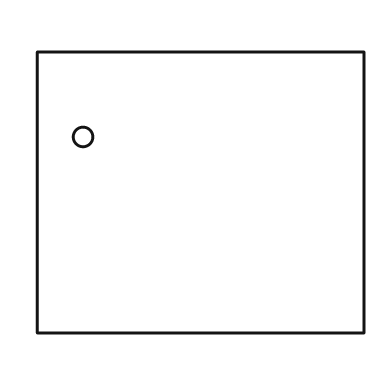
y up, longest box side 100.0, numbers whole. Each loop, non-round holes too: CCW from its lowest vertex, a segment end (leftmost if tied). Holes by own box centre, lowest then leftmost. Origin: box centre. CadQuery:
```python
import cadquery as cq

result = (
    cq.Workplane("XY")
    .moveTo(-50.0, -43.0)
    .lineTo(50.0, -43.0)
    .lineTo(50.0, 43.0)
    .lineTo(-50.0, 43.0)
    .close()
    .moveTo(-36.0, 17.0)
    .circle(3.0)
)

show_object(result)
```